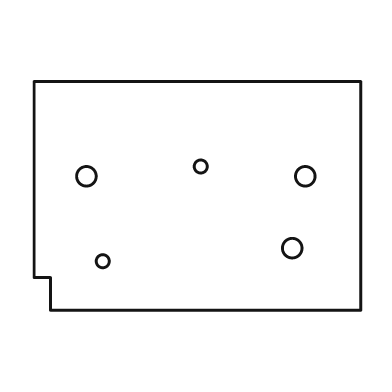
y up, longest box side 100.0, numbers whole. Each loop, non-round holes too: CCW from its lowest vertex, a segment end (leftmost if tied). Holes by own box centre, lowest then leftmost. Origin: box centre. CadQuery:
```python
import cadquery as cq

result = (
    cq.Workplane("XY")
    .moveTo(-45.0, -35.0)
    .lineTo(50.0, -35.0)
    .lineTo(50.0, 35.0)
    .lineTo(-50.0, 35.0)
    .lineTo(-50.0, -25.0)
    .lineTo(-45.0, -25.0)
    .close()
    .moveTo(-29.0, -20.0)
    .circle(2.0)
    .moveTo(29.0, -16.0)
    .circle(3.0)
    .moveTo(-34.0, 6.0)
    .circle(3.0)
    .moveTo(33.0, 6.0)
    .circle(3.0)
    .moveTo(1.0, 9.0)
    .circle(2.0)
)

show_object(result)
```